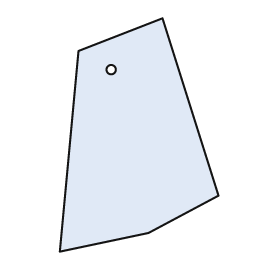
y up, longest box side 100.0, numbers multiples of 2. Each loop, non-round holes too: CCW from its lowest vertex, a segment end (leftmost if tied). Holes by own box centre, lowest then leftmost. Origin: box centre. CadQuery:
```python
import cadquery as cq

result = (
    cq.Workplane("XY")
    .moveTo(-34.0, -50.0)
    .lineTo(4.0, -42.0)
    .lineTo(34.0, -26.0)
    .lineTo(10.0, 50.0)
    .lineTo(-26.0, 36.0)
    .close()
    .moveTo(-12.0, 28.0)
    .circle(2.0)
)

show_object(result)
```